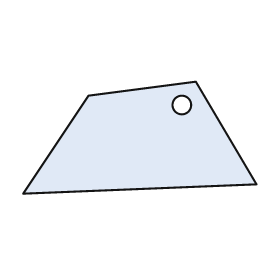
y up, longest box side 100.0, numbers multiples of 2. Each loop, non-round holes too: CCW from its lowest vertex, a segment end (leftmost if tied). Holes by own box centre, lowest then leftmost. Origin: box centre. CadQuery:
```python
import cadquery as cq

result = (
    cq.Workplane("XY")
    .moveTo(-50.0, -24.0)
    .lineTo(50.0, -20.0)
    .lineTo(24.0, 24.0)
    .lineTo(-22.0, 18.0)
    .close()
    .moveTo(18.0, 14.0)
    .circle(4.0)
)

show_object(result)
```